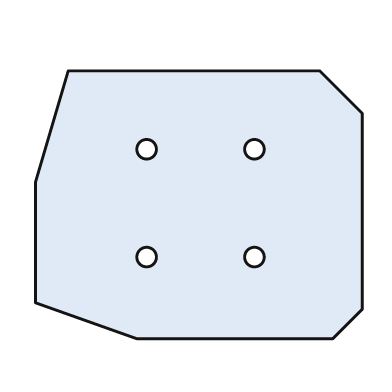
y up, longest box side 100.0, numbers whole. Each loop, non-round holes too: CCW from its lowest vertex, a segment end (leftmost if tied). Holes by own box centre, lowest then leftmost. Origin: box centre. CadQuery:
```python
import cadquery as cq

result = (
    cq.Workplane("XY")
    .moveTo(-19.0, -41.0)
    .lineTo(41.0, -41.0)
    .lineTo(50.0, -32.0)
    .lineTo(50.0, 28.0)
    .lineTo(37.0, 41.0)
    .lineTo(-40.0, 41.0)
    .lineTo(-50.0, 7.0)
    .lineTo(-50.0, -30.0)
    .close()
    .moveTo(-16.0, -16.0)
    .circle(3.0)
    .moveTo(17.0, -16.0)
    .circle(3.0)
    .moveTo(-16.0, 17.0)
    .circle(3.0)
    .moveTo(17.0, 17.0)
    .circle(3.0)
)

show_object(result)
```